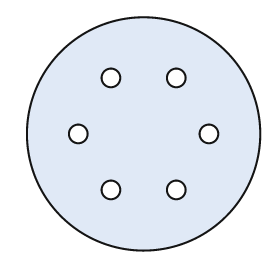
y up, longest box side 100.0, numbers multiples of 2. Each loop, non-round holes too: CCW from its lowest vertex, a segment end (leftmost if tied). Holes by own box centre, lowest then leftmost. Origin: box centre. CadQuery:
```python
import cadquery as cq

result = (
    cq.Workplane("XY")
    .moveTo(0.0, 0.0)
    .circle(50.0)
    .moveTo(-14.0, -24.0)
    .circle(4.0)
    .moveTo(14.0, -24.0)
    .circle(4.0)
    .moveTo(-28.0, 0.0)
    .circle(4.0)
    .moveTo(28.0, 0.0)
    .circle(4.0)
    .moveTo(-14.0, 24.0)
    .circle(4.0)
    .moveTo(14.0, 24.0)
    .circle(4.0)
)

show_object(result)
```